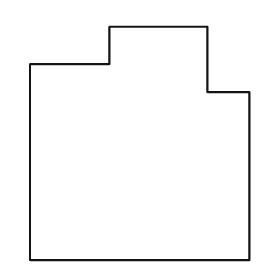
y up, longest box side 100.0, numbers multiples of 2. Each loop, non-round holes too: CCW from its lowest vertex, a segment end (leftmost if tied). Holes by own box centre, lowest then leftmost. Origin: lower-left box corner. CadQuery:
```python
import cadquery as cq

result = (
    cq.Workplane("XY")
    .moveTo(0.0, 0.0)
    .lineTo(94.0, 0.0)
    .lineTo(94.0, 72.0)
    .lineTo(76.0, 72.0)
    .lineTo(76.0, 100.0)
    .lineTo(34.0, 100.0)
    .lineTo(34.0, 84.0)
    .lineTo(0.0, 84.0)
    .close()
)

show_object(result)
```